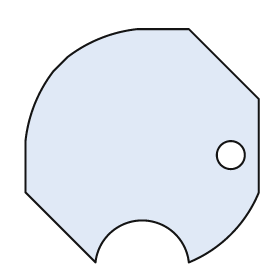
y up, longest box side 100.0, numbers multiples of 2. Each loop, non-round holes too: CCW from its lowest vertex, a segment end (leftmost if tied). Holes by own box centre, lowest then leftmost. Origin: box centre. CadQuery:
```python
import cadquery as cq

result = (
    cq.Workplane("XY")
    .moveTo(-20.0, -50.0)
    .threePointArc((0.0, -32.0), (20.0, -50.0))
    .threePointArc((38.0, -38.0), (50.0, -20.0))
    .lineTo(50.0, 20.0)
    .lineTo(20.0, 50.0)
    .lineTo(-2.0, 50.0)
    .threePointArc((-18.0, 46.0), (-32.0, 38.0))
    .lineTo(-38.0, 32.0)
    .threePointArc((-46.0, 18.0), (-50.0, 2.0))
    .lineTo(-50.0, -20.0)
    .close()
    .moveTo(38.0, -4.0)
    .circle(6.0)
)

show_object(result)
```